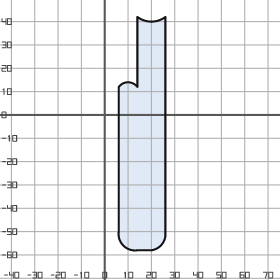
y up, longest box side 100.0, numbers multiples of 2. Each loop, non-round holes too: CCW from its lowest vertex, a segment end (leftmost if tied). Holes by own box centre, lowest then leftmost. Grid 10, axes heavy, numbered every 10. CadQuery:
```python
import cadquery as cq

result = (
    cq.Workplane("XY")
    .moveTo(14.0, -58.0)
    .lineTo(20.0, -58.0)
    .threePointArc((24.0, -56.0), (26.0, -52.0))
    .lineTo(26.0, 42.0)
    .threePointArc((20.0, 40.0), (14.0, 42.0))
    .lineTo(14.0, 12.0)
    .threePointArc((10.0, 14.0), (6.0, 12.0))
    .lineTo(6.0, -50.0)
    .threePointArc((8.0, -56.0), (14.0, -58.0))
    .close()
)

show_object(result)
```